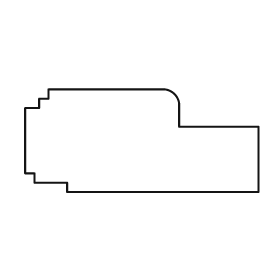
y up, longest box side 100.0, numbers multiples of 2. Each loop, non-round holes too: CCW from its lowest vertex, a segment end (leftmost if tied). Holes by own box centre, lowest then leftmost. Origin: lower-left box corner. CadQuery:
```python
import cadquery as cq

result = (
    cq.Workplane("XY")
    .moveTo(18.0, 0.0)
    .lineTo(100.0, 0.0)
    .lineTo(100.0, 28.0)
    .lineTo(66.0, 28.0)
    .lineTo(66.0, 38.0)
    .threePointArc((64.0, 42.0), (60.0, 44.0))
    .lineTo(10.0, 44.0)
    .lineTo(10.0, 40.0)
    .lineTo(6.0, 40.0)
    .lineTo(6.0, 36.0)
    .lineTo(0.0, 36.0)
    .lineTo(0.0, 8.0)
    .lineTo(4.0, 8.0)
    .lineTo(4.0, 4.0)
    .lineTo(18.0, 4.0)
    .close()
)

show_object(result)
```